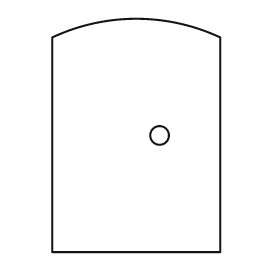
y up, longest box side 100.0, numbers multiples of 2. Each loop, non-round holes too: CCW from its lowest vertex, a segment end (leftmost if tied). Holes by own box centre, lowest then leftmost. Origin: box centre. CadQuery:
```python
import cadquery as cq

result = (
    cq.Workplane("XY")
    .moveTo(-36.0, -50.0)
    .lineTo(36.0, -50.0)
    .lineTo(36.0, 42.0)
    .threePointArc((0.0, 50.0), (-36.0, 42.0))
    .close()
    .moveTo(10.0, 0.0)
    .circle(4.0)
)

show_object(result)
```